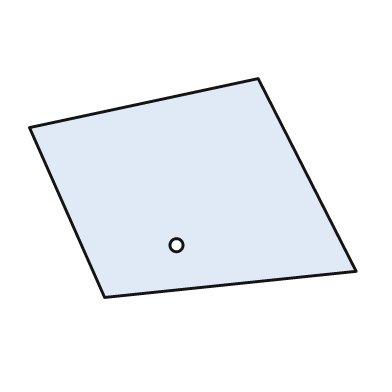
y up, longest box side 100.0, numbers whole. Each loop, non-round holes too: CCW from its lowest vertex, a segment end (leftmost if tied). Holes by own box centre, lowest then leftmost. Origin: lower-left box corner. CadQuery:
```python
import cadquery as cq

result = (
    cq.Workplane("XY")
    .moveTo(23.0, 0.0)
    .lineTo(100.0, 8.0)
    .lineTo(70.0, 67.0)
    .lineTo(0.0, 52.0)
    .close()
    .moveTo(45.0, 16.0)
    .circle(2.0)
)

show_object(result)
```